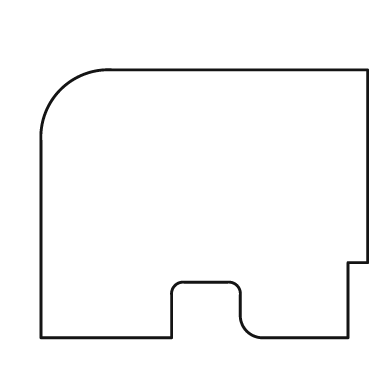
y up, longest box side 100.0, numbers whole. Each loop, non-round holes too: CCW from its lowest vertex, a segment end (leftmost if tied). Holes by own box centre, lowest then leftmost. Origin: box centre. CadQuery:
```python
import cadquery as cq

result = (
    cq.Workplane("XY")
    .moveTo(-50.0, -41.0)
    .lineTo(-10.0, -41.0)
    .lineTo(-10.0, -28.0)
    .threePointArc((-9.0, -25.0), (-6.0, -24.0))
    .lineTo(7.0, -24.0)
    .threePointArc((10.0, -25.0), (11.0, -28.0))
    .lineTo(11.0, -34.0)
    .threePointArc((13.0, -39.0), (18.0, -41.0))
    .lineTo(44.0, -41.0)
    .lineTo(44.0, -18.0)
    .lineTo(50.0, -18.0)
    .lineTo(50.0, 41.0)
    .lineTo(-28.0, 41.0)
    .threePointArc((-44.0, 35.0), (-50.0, 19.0))
    .close()
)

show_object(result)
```